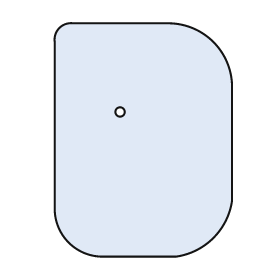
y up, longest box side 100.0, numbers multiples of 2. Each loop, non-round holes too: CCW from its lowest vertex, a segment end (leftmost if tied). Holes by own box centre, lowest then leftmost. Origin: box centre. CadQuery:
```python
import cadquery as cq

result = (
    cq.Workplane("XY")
    .moveTo(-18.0, -50.0)
    .lineTo(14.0, -50.0)
    .threePointArc((30.0, -42.0), (38.0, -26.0))
    .lineTo(38.0, 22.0)
    .threePointArc((30.0, 42.0), (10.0, 50.0))
    .lineTo(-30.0, 50.0)
    .threePointArc((-36.0, 48.0), (-38.0, 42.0))
    .lineTo(-38.0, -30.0)
    .threePointArc((-32.0, -44.0), (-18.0, -50.0))
    .close()
    .moveTo(-10.0, 12.0)
    .circle(2.0)
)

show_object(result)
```